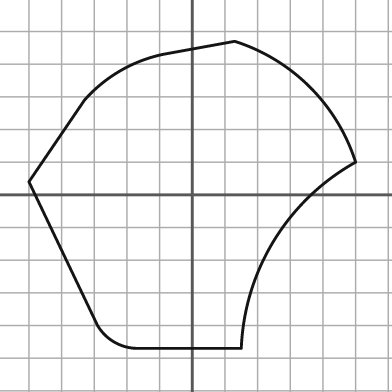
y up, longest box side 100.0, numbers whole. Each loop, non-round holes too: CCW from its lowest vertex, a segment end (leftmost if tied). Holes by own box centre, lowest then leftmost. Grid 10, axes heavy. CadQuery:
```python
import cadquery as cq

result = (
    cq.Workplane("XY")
    .moveTo(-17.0, -47.0)
    .lineTo(15.0, -47.0)
    .threePointArc((25.0, -14.0), (50.0, 10.0))
    .threePointArc((36.0, 33.0), (13.0, 47.0))
    .lineTo(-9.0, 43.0)
    .threePointArc((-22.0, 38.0), (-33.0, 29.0))
    .lineTo(-50.0, 4.0)
    .lineTo(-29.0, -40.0)
    .threePointArc((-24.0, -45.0), (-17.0, -47.0))
    .close()
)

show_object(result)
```